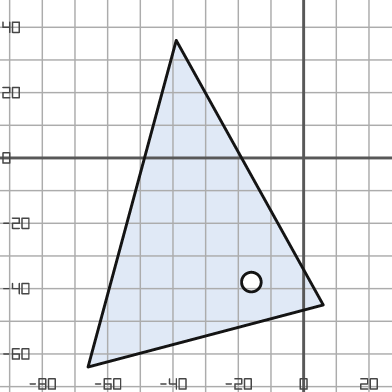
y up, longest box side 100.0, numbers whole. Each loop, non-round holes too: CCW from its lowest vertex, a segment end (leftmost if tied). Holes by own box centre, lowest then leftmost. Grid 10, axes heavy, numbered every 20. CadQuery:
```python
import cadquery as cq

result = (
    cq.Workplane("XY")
    .moveTo(-66.0, -64.0)
    .lineTo(6.0, -45.0)
    .lineTo(-39.0, 36.0)
    .close()
    .moveTo(-16.0, -38.0)
    .circle(3.0)
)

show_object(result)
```